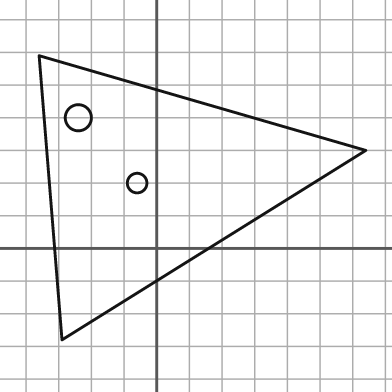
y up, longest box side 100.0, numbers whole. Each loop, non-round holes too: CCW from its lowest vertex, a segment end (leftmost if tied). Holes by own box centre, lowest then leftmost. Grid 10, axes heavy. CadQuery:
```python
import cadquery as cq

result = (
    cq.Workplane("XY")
    .moveTo(-29.0, -28.0)
    .lineTo(64.0, 30.0)
    .lineTo(-36.0, 59.0)
    .close()
    .moveTo(-6.0, 20.0)
    .circle(3.0)
    .moveTo(-24.0, 40.0)
    .circle(4.0)
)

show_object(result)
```